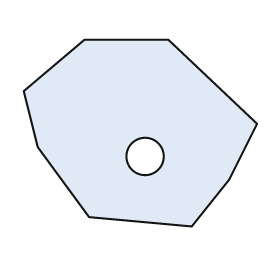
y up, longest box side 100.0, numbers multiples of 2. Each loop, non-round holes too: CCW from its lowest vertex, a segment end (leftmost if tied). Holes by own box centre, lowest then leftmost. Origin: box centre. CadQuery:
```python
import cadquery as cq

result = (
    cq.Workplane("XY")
    .moveTo(22.0, -40.0)
    .lineTo(38.0, -20.0)
    .lineTo(50.0, 4.0)
    .lineTo(12.0, 40.0)
    .lineTo(-24.0, 40.0)
    .lineTo(-50.0, 18.0)
    .lineTo(-44.0, -6.0)
    .lineTo(-22.0, -36.0)
    .close()
    .moveTo(2.0, -10.0)
    .circle(8.0)
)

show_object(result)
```